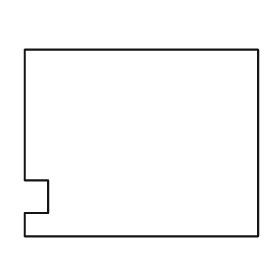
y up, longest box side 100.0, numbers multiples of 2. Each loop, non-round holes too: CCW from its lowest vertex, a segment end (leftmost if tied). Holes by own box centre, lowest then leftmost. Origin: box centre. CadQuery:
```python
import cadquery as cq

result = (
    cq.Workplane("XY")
    .moveTo(-50.0, -40.0)
    .lineTo(50.0, -40.0)
    .lineTo(50.0, 40.0)
    .lineTo(-50.0, 40.0)
    .lineTo(-50.0, -16.0)
    .lineTo(-40.0, -16.0)
    .lineTo(-40.0, -30.0)
    .lineTo(-50.0, -30.0)
    .close()
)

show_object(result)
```